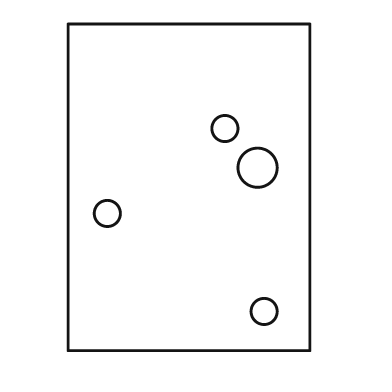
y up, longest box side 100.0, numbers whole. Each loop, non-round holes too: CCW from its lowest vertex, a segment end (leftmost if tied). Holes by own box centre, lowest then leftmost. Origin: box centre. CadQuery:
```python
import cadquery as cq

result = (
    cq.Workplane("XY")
    .moveTo(-37.0, -50.0)
    .lineTo(37.0, -50.0)
    .lineTo(37.0, 50.0)
    .lineTo(-37.0, 50.0)
    .close()
    .moveTo(23.0, -38.0)
    .circle(4.0)
    .moveTo(-25.0, -8.0)
    .circle(4.0)
    .moveTo(21.0, 6.0)
    .circle(6.0)
    .moveTo(11.0, 18.0)
    .circle(4.0)
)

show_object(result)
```